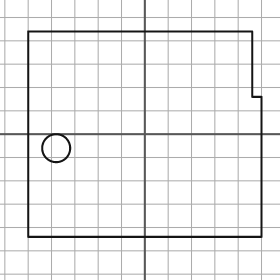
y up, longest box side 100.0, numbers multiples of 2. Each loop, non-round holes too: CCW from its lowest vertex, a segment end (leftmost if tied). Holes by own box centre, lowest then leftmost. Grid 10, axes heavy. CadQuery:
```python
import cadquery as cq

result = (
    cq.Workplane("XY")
    .moveTo(-50.0, -44.0)
    .lineTo(50.0, -44.0)
    .lineTo(50.0, 16.0)
    .lineTo(46.0, 16.0)
    .lineTo(46.0, 44.0)
    .lineTo(-50.0, 44.0)
    .close()
    .moveTo(-38.0, -6.0)
    .circle(6.0)
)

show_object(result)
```